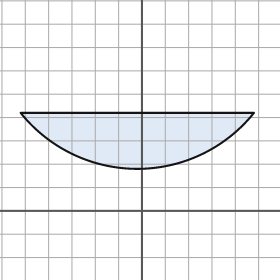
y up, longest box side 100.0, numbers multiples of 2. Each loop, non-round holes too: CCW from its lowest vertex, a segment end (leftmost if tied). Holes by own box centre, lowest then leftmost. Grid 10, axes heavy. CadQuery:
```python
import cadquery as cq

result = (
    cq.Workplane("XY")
    .moveTo(-52.0, 42.0)
    .threePointArc((-2.0, 18.0), (48.0, 42.0))
    .close()
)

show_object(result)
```